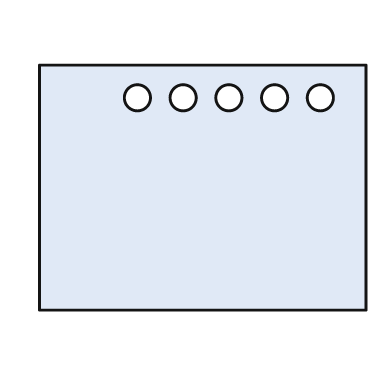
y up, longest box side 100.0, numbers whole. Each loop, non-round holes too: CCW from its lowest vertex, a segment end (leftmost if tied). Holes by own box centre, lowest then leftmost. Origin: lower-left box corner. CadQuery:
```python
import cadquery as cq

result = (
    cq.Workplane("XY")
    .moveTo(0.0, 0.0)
    .lineTo(100.0, 0.0)
    .lineTo(100.0, 75.0)
    .lineTo(0.0, 75.0)
    .close()
    .moveTo(30.0, 65.0)
    .circle(4.0)
    .moveTo(44.0, 65.0)
    .circle(4.0)
    .moveTo(58.0, 65.0)
    .circle(4.0)
    .moveTo(72.0, 65.0)
    .circle(4.0)
    .moveTo(86.0, 65.0)
    .circle(4.0)
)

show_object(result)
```